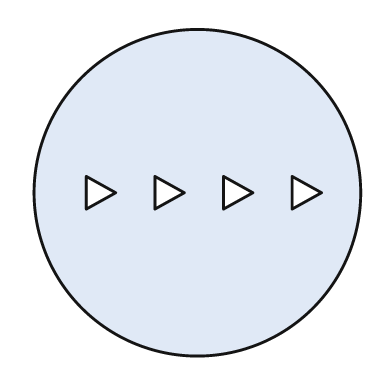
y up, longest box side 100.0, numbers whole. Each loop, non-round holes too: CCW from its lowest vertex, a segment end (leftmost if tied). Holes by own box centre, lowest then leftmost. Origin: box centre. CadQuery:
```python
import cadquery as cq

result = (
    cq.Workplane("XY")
    .moveTo(0.0, 0.0)
    .circle(50.0)
    .moveTo(-34.0, -5.0)
    .lineTo(-25.0, 0.0)
    .lineTo(-34.0, 5.0)
    .close()
    .moveTo(-13.0, -5.0)
    .lineTo(-4.0, 0.0)
    .lineTo(-13.0, 5.0)
    .close()
    .moveTo(8.0, -5.0)
    .lineTo(17.0, 0.0)
    .lineTo(8.0, 5.0)
    .close()
    .moveTo(29.0, -5.0)
    .lineTo(38.0, 0.0)
    .lineTo(29.0, 5.0)
    .close()
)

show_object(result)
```